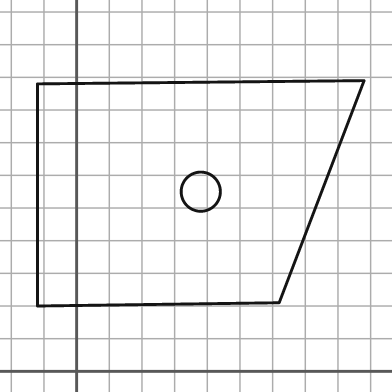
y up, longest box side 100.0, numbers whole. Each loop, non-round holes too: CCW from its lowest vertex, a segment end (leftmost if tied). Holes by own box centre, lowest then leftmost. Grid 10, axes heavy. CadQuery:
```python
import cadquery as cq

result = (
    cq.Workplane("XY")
    .moveTo(-12.0, 20.0)
    .lineTo(62.0, 21.0)
    .lineTo(88.0, 89.0)
    .lineTo(-12.0, 88.0)
    .close()
    .moveTo(38.0, 55.0)
    .circle(6.0)
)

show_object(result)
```